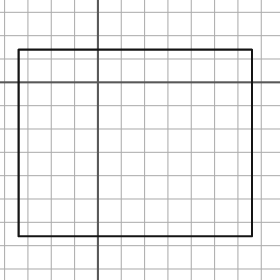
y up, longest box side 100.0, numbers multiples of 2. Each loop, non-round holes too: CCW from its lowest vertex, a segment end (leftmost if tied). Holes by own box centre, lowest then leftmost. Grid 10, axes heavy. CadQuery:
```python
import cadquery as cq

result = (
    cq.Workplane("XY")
    .moveTo(-34.0, -66.0)
    .lineTo(66.0, -66.0)
    .lineTo(66.0, 14.0)
    .lineTo(-34.0, 14.0)
    .close()
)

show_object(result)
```